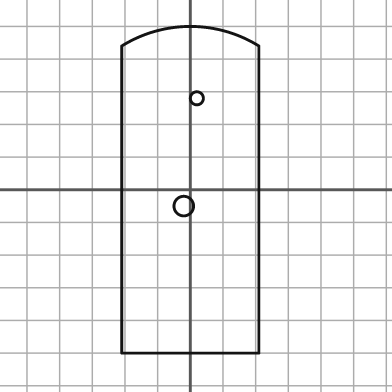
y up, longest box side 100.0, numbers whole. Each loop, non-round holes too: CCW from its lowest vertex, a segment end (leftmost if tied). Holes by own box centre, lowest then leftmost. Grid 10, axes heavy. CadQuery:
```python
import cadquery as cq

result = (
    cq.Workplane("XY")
    .moveTo(-21.0, -50.0)
    .lineTo(21.0, -50.0)
    .lineTo(21.0, 44.0)
    .threePointArc((0.0, 50.0), (-21.0, 44.0))
    .close()
    .moveTo(-2.0, -5.0)
    .circle(3.0)
    .moveTo(2.0, 28.0)
    .circle(2.0)
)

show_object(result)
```